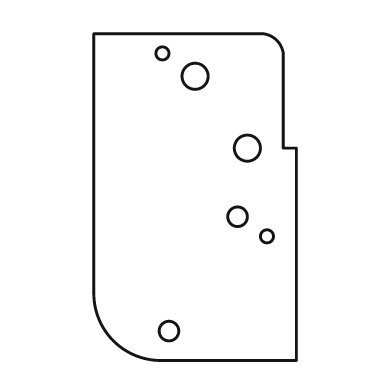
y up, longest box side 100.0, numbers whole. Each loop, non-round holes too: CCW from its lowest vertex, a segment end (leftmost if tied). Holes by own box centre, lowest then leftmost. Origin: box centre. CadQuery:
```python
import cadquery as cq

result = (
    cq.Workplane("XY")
    .moveTo(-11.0, -50.0)
    .lineTo(31.0, -50.0)
    .lineTo(31.0, 15.0)
    .lineTo(27.0, 15.0)
    .lineTo(27.0, 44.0)
    .threePointArc((25.0, 48.0), (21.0, 50.0))
    .lineTo(-31.0, 50.0)
    .lineTo(-31.0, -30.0)
    .threePointArc((-25.0, -44.0), (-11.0, -50.0))
    .close()
    .moveTo(-8.0, -41.0)
    .circle(3.0)
    .moveTo(22.0, -12.0)
    .circle(2.0)
    .moveTo(13.0, -6.0)
    .circle(3.0)
    .moveTo(16.0, 15.0)
    .circle(4.0)
    .moveTo(0.0, 37.0)
    .circle(4.0)
    .moveTo(-10.0, 44.0)
    .circle(2.0)
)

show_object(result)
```